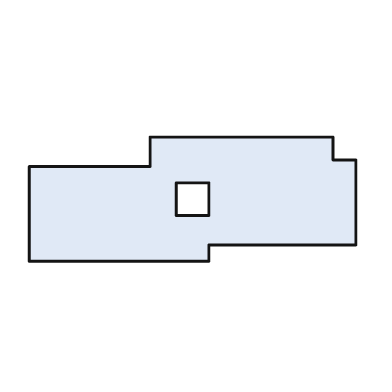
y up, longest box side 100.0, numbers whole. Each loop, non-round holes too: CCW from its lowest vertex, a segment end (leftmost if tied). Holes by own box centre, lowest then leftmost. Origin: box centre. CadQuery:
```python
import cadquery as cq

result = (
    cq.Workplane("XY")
    .moveTo(-50.0, -19.0)
    .lineTo(5.0, -19.0)
    .lineTo(5.0, -14.0)
    .lineTo(50.0, -14.0)
    .lineTo(50.0, 12.0)
    .lineTo(43.0, 12.0)
    .lineTo(43.0, 19.0)
    .lineTo(-13.0, 19.0)
    .lineTo(-13.0, 10.0)
    .lineTo(-50.0, 10.0)
    .close()
    .moveTo(-5.0, -5.0)
    .lineTo(5.0, -5.0)
    .lineTo(5.0, 5.0)
    .lineTo(-5.0, 5.0)
    .close()
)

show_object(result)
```